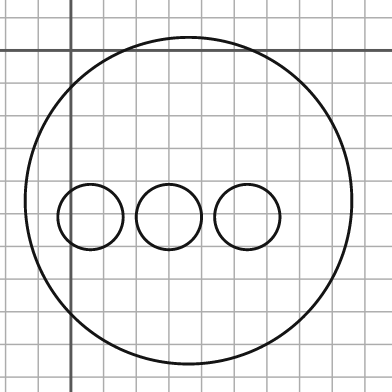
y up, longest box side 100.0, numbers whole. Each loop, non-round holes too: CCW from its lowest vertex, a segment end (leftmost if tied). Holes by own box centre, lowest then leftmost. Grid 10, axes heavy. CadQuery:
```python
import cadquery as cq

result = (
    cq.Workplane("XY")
    .moveTo(36.0, -46.0)
    .circle(50.0)
    .moveTo(6.0, -51.0)
    .circle(10.0)
    .moveTo(30.0, -51.0)
    .circle(10.0)
    .moveTo(54.0, -51.0)
    .circle(10.0)
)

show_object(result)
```